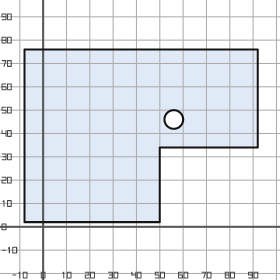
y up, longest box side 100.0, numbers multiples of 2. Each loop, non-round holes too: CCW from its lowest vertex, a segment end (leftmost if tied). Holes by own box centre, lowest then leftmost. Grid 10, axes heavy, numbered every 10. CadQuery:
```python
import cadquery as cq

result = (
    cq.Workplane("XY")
    .moveTo(-8.0, 2.0)
    .lineTo(50.0, 2.0)
    .lineTo(50.0, 34.0)
    .lineTo(92.0, 34.0)
    .lineTo(92.0, 76.0)
    .lineTo(-8.0, 76.0)
    .close()
    .moveTo(56.0, 46.0)
    .circle(4.0)
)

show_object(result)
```